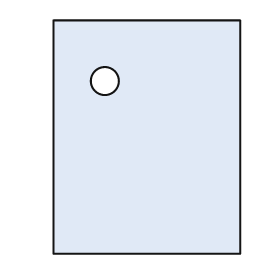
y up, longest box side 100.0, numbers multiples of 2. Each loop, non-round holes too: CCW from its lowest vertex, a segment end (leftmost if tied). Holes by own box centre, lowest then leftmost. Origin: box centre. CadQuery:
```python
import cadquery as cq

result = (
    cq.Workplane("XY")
    .moveTo(-40.0, -50.0)
    .lineTo(40.0, -50.0)
    .lineTo(40.0, 50.0)
    .lineTo(-40.0, 50.0)
    .close()
    .moveTo(-18.0, 24.0)
    .circle(6.0)
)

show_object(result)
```